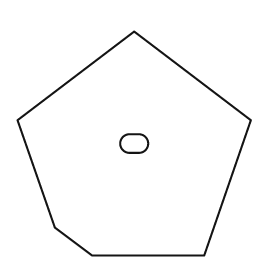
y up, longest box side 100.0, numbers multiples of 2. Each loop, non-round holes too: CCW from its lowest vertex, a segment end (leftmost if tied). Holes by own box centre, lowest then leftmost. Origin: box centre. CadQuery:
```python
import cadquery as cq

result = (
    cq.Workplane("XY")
    .moveTo(-18.0, -48.0)
    .lineTo(30.0, -48.0)
    .lineTo(50.0, 10.0)
    .lineTo(0.0, 48.0)
    .lineTo(-50.0, 10.0)
    .lineTo(-34.0, -36.0)
    .close()
    .moveTo(-2.0, -4.0)
    .lineTo(2.0, -4.0)
    .threePointArc((6.0, 0.0), (2.0, 4.0))
    .lineTo(-2.0, 4.0)
    .threePointArc((-6.0, 0.0), (-2.0, -4.0))
    .close()
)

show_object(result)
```